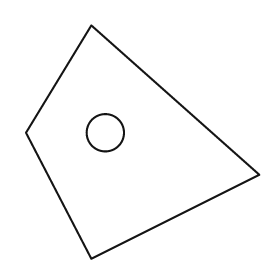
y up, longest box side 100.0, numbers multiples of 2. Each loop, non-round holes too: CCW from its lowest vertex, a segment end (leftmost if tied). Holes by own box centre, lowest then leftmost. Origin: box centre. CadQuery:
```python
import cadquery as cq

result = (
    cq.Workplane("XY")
    .moveTo(-22.0, -50.0)
    .lineTo(50.0, -14.0)
    .lineTo(-22.0, 50.0)
    .lineTo(-50.0, 4.0)
    .close()
    .moveTo(-16.0, 4.0)
    .circle(8.0)
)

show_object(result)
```